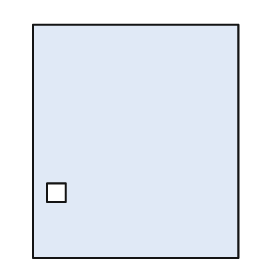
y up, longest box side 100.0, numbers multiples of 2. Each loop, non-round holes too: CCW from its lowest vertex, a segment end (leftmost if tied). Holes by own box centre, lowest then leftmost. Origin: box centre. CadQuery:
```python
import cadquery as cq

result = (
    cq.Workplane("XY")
    .moveTo(-44.0, -50.0)
    .lineTo(44.0, -50.0)
    .lineTo(44.0, 50.0)
    .lineTo(-44.0, 50.0)
    .close()
    .moveTo(-38.0, -26.0)
    .lineTo(-30.0, -26.0)
    .lineTo(-30.0, -18.0)
    .lineTo(-38.0, -18.0)
    .close()
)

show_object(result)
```